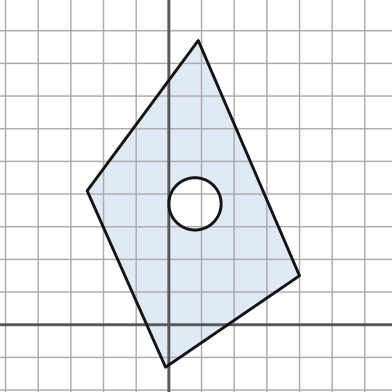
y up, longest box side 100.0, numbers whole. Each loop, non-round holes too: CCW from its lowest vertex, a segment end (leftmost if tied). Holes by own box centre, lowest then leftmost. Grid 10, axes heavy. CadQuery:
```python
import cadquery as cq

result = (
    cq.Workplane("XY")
    .moveTo(-1.0, -13.0)
    .lineTo(40.0, 15.0)
    .lineTo(9.0, 87.0)
    .lineTo(-25.0, 41.0)
    .close()
    .moveTo(8.0, 37.0)
    .circle(8.0)
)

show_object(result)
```